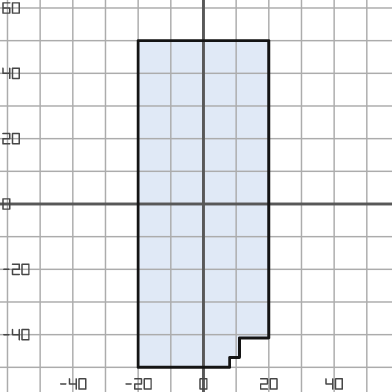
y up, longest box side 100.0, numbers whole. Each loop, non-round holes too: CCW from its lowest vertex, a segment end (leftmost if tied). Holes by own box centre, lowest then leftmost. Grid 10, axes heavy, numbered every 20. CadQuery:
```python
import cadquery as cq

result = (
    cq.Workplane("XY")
    .moveTo(-20.0, -50.0)
    .lineTo(8.0, -50.0)
    .lineTo(8.0, -47.0)
    .lineTo(11.0, -47.0)
    .lineTo(11.0, -41.0)
    .lineTo(20.0, -41.0)
    .lineTo(20.0, 50.0)
    .lineTo(-20.0, 50.0)
    .close()
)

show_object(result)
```